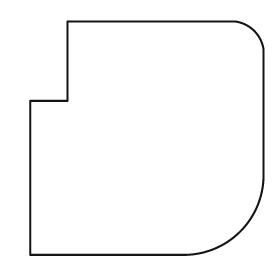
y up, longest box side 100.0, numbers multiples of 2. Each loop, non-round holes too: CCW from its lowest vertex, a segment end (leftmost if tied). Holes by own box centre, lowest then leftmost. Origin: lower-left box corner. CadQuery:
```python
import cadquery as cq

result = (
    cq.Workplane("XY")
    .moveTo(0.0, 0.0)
    .lineTo(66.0, 0.0)
    .threePointArc((90.0, 10.0), (100.0, 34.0))
    .lineTo(100.0, 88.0)
    .threePointArc((96.0, 96.0), (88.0, 100.0))
    .lineTo(16.0, 100.0)
    .lineTo(16.0, 66.0)
    .lineTo(0.0, 66.0)
    .close()
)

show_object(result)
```